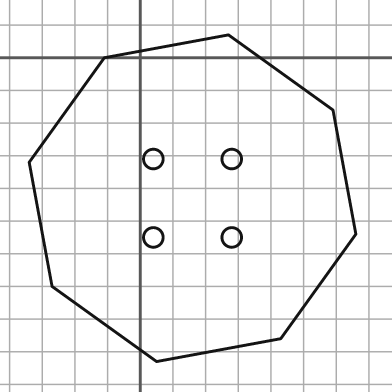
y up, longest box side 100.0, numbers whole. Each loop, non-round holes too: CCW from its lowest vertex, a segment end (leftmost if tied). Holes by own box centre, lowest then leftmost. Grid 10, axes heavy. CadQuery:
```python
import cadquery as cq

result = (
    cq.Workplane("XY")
    .moveTo(5.0, -93.0)
    .lineTo(43.0, -86.0)
    .lineTo(66.0, -54.0)
    .lineTo(59.0, -16.0)
    .lineTo(27.0, 7.0)
    .lineTo(-11.0, 0.0)
    .lineTo(-34.0, -32.0)
    .lineTo(-27.0, -70.0)
    .close()
    .moveTo(4.0, -55.0)
    .circle(3.0)
    .moveTo(28.0, -55.0)
    .circle(3.0)
    .moveTo(4.0, -31.0)
    .circle(3.0)
    .moveTo(28.0, -31.0)
    .circle(3.0)
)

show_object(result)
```